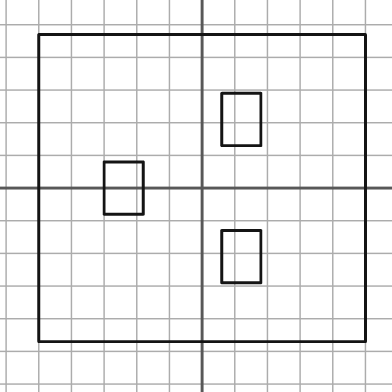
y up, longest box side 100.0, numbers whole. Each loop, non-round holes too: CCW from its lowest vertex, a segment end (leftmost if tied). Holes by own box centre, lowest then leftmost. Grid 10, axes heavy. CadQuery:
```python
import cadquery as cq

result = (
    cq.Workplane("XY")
    .moveTo(-50.0, -47.0)
    .lineTo(50.0, -47.0)
    .lineTo(50.0, 47.0)
    .lineTo(-50.0, 47.0)
    .close()
    .moveTo(6.0, -29.0)
    .lineTo(18.0, -29.0)
    .lineTo(18.0, -13.0)
    .lineTo(6.0, -13.0)
    .close()
    .moveTo(-30.0, -8.0)
    .lineTo(-18.0, -8.0)
    .lineTo(-18.0, 8.0)
    .lineTo(-30.0, 8.0)
    .close()
    .moveTo(6.0, 13.0)
    .lineTo(18.0, 13.0)
    .lineTo(18.0, 29.0)
    .lineTo(6.0, 29.0)
    .close()
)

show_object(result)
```